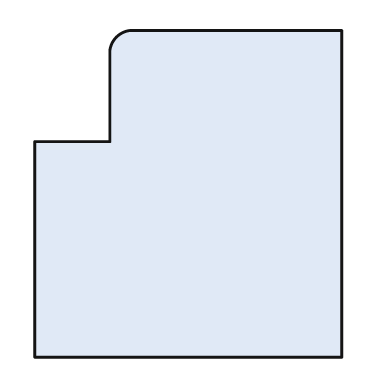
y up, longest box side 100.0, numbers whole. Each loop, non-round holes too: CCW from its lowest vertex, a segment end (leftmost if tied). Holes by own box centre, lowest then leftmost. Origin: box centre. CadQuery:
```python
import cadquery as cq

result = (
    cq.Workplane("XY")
    .moveTo(-47.0, -50.0)
    .lineTo(47.0, -50.0)
    .lineTo(47.0, 50.0)
    .lineTo(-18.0, 50.0)
    .threePointArc((-22.0, 48.0), (-24.0, 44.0))
    .lineTo(-24.0, 16.0)
    .lineTo(-47.0, 16.0)
    .close()
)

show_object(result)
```